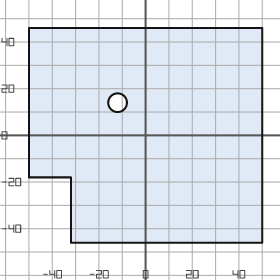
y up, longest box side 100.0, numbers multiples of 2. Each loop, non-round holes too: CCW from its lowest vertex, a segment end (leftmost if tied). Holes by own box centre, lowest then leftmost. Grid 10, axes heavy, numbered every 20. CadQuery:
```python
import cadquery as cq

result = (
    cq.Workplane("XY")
    .moveTo(-32.0, -46.0)
    .lineTo(50.0, -46.0)
    .lineTo(50.0, 46.0)
    .lineTo(-50.0, 46.0)
    .lineTo(-50.0, -18.0)
    .lineTo(-32.0, -18.0)
    .close()
    .moveTo(-12.0, 14.0)
    .circle(4.0)
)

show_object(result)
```